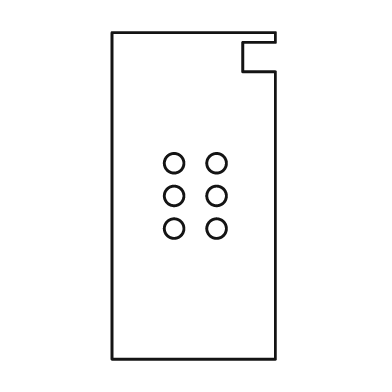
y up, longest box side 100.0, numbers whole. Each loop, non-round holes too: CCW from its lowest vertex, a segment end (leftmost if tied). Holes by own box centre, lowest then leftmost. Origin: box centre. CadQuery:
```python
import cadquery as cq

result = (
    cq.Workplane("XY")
    .moveTo(-25.0, -50.0)
    .lineTo(25.0, -50.0)
    .lineTo(25.0, 38.0)
    .lineTo(15.0, 38.0)
    .lineTo(15.0, 47.0)
    .lineTo(25.0, 47.0)
    .lineTo(25.0, 50.0)
    .lineTo(-25.0, 50.0)
    .close()
    .moveTo(-6.0, -10.0)
    .circle(3.0)
    .moveTo(7.0, -10.0)
    .circle(3.0)
    .moveTo(-6.0, 0.0)
    .circle(3.0)
    .moveTo(7.0, 0.0)
    .circle(3.0)
    .moveTo(-6.0, 10.0)
    .circle(3.0)
    .moveTo(7.0, 10.0)
    .circle(3.0)
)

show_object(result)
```